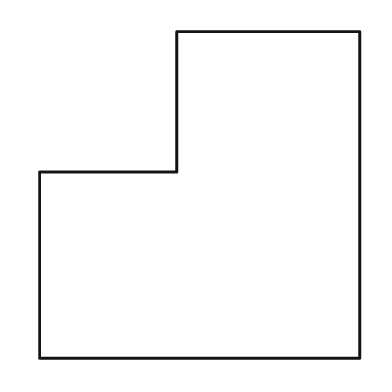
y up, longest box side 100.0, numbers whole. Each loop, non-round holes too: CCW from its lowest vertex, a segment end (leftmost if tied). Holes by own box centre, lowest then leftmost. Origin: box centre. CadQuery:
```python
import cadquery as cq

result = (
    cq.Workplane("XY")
    .moveTo(-49.0, -50.0)
    .lineTo(49.0, -50.0)
    .lineTo(49.0, 50.0)
    .lineTo(-7.0, 50.0)
    .lineTo(-7.0, 7.0)
    .lineTo(-49.0, 7.0)
    .close()
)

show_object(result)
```